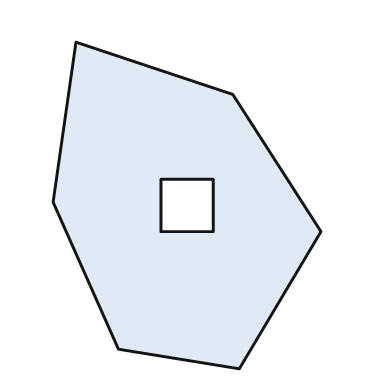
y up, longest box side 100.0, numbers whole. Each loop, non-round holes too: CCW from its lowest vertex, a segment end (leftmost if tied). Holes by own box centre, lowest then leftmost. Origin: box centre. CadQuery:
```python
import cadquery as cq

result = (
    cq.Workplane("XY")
    .moveTo(16.0, -50.0)
    .lineTo(41.0, -8.0)
    .lineTo(14.0, 34.0)
    .lineTo(-34.0, 50.0)
    .lineTo(-41.0, 1.0)
    .lineTo(-21.0, -44.0)
    .close()
    .moveTo(-8.0, -8.0)
    .lineTo(8.0, -8.0)
    .lineTo(8.0, 8.0)
    .lineTo(-8.0, 8.0)
    .close()
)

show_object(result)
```